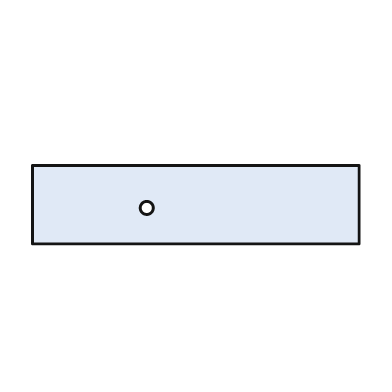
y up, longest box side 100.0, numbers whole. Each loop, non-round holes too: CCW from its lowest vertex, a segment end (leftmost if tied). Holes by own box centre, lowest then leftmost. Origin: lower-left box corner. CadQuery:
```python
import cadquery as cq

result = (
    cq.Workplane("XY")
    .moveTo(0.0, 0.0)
    .lineTo(100.0, 0.0)
    .lineTo(100.0, 24.0)
    .lineTo(0.0, 24.0)
    .close()
    .moveTo(35.0, 11.0)
    .circle(2.0)
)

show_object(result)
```